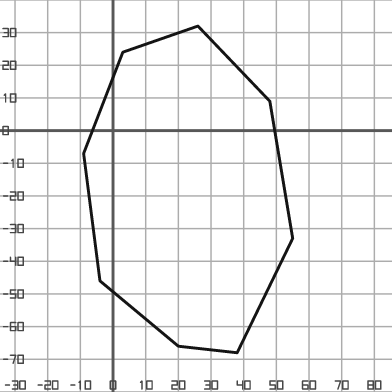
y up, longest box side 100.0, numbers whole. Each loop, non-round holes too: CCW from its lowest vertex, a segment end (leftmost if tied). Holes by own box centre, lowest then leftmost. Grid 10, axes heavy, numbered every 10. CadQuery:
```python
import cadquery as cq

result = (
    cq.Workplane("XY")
    .moveTo(38.0, -68.0)
    .lineTo(55.0, -33.0)
    .lineTo(48.0, 9.0)
    .lineTo(26.0, 32.0)
    .lineTo(3.0, 24.0)
    .lineTo(-9.0, -7.0)
    .lineTo(-4.0, -46.0)
    .lineTo(20.0, -66.0)
    .close()
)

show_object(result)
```